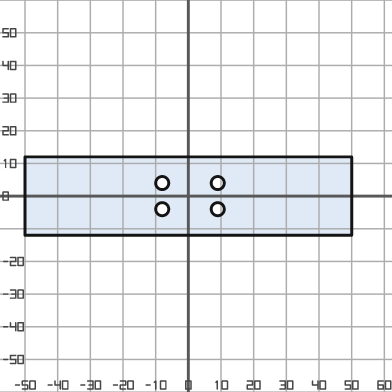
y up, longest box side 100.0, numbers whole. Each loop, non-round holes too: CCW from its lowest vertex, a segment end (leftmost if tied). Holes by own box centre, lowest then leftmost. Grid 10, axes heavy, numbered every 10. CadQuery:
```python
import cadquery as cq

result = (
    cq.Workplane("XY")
    .moveTo(-50.0, -12.0)
    .lineTo(50.0, -12.0)
    .lineTo(50.0, 12.0)
    .lineTo(-50.0, 12.0)
    .close()
    .moveTo(-8.0, -4.0)
    .circle(2.0)
    .moveTo(9.0, -4.0)
    .circle(2.0)
    .moveTo(-8.0, 4.0)
    .circle(2.0)
    .moveTo(9.0, 4.0)
    .circle(2.0)
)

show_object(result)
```